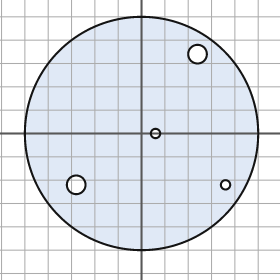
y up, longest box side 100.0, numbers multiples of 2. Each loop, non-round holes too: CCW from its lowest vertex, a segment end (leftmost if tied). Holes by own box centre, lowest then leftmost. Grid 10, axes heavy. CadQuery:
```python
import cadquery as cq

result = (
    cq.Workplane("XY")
    .moveTo(0.0, 0.0)
    .circle(50.0)
    .moveTo(-28.0, -22.0)
    .circle(4.0)
    .moveTo(36.0, -22.0)
    .circle(2.0)
    .moveTo(6.0, 0.0)
    .circle(2.0)
    .moveTo(24.0, 34.0)
    .circle(4.0)
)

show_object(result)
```